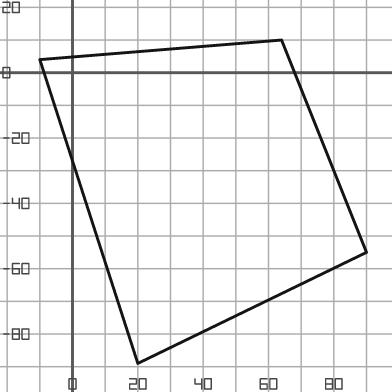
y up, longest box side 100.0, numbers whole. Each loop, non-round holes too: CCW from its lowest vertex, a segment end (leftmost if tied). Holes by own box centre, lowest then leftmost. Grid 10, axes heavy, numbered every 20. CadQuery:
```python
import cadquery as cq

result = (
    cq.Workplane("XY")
    .moveTo(20.0, -89.0)
    .lineTo(90.0, -55.0)
    .lineTo(64.0, 10.0)
    .lineTo(-10.0, 4.0)
    .close()
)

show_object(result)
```